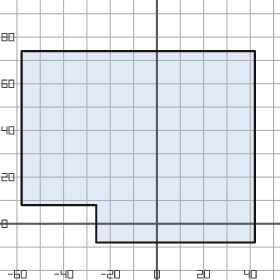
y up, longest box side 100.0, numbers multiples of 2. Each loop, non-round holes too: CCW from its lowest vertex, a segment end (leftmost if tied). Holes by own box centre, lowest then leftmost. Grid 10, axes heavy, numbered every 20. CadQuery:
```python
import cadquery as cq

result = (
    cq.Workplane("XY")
    .moveTo(-26.0, -8.0)
    .lineTo(42.0, -8.0)
    .lineTo(42.0, 74.0)
    .lineTo(-58.0, 74.0)
    .lineTo(-58.0, 8.0)
    .lineTo(-26.0, 8.0)
    .close()
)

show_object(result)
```